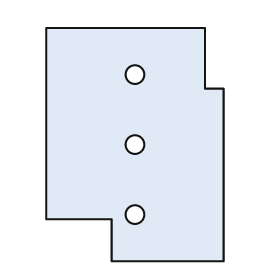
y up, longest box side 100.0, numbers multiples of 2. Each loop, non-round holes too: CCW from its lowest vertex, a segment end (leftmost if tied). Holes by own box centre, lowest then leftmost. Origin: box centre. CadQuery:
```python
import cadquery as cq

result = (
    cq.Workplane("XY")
    .moveTo(-10.0, -50.0)
    .lineTo(38.0, -50.0)
    .lineTo(38.0, 24.0)
    .lineTo(30.0, 24.0)
    .lineTo(30.0, 50.0)
    .lineTo(-38.0, 50.0)
    .lineTo(-38.0, -32.0)
    .lineTo(-10.0, -32.0)
    .close()
    .moveTo(0.0, -30.0)
    .circle(4.0)
    .moveTo(0.0, 0.0)
    .circle(4.0)
    .moveTo(0.0, 30.0)
    .circle(4.0)
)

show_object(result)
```